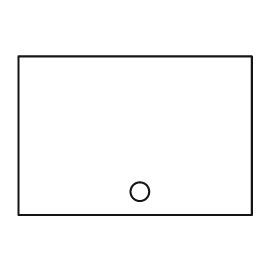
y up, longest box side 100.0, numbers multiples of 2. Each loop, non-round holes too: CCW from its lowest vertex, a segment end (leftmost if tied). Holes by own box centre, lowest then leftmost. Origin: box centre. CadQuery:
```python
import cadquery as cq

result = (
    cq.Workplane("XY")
    .moveTo(-50.0, -34.0)
    .lineTo(50.0, -34.0)
    .lineTo(50.0, 34.0)
    .lineTo(-50.0, 34.0)
    .close()
    .moveTo(2.0, -24.0)
    .circle(4.0)
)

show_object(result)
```